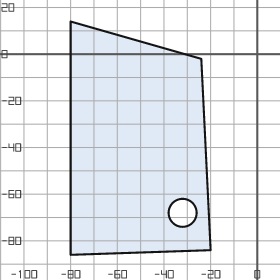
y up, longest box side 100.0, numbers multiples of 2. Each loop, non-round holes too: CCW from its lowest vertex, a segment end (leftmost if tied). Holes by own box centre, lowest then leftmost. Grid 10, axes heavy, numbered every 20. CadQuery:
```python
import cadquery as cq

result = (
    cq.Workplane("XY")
    .moveTo(-80.0, -86.0)
    .lineTo(-20.0, -84.0)
    .lineTo(-24.0, -2.0)
    .lineTo(-80.0, 14.0)
    .close()
    .moveTo(-32.0, -68.0)
    .circle(6.0)
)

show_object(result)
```